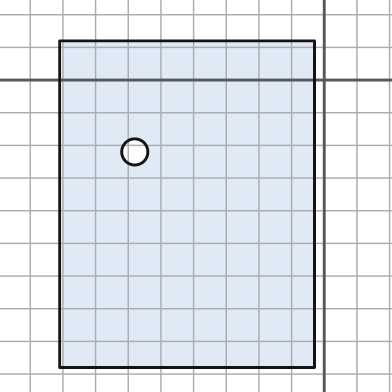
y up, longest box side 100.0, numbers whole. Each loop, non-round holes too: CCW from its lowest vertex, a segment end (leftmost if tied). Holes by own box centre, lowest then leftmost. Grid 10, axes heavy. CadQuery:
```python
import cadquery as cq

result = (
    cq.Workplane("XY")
    .moveTo(-81.0, -88.0)
    .lineTo(-3.0, -88.0)
    .lineTo(-3.0, 12.0)
    .lineTo(-81.0, 12.0)
    .close()
    .moveTo(-58.0, -22.0)
    .circle(4.0)
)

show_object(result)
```